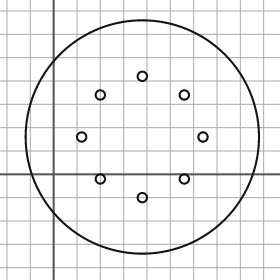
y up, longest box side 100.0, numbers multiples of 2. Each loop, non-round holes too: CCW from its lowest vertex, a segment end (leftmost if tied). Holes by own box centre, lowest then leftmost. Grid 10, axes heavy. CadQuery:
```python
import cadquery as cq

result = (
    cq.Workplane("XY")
    .moveTo(38.0, 16.0)
    .circle(50.0)
    .moveTo(38.0, -10.0)
    .circle(2.0)
    .moveTo(20.0, -2.0)
    .circle(2.0)
    .moveTo(56.0, -2.0)
    .circle(2.0)
    .moveTo(12.0, 16.0)
    .circle(2.0)
    .moveTo(64.0, 16.0)
    .circle(2.0)
    .moveTo(20.0, 34.0)
    .circle(2.0)
    .moveTo(56.0, 34.0)
    .circle(2.0)
    .moveTo(38.0, 42.0)
    .circle(2.0)
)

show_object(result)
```